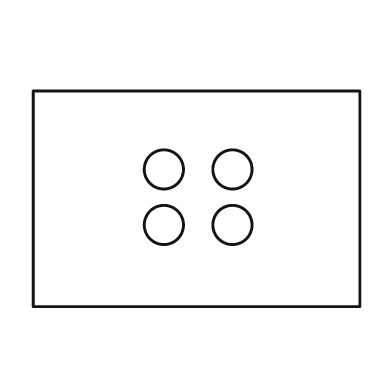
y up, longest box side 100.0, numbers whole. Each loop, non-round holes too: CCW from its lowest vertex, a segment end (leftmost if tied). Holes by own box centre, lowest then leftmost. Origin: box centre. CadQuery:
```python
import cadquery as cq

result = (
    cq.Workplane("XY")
    .moveTo(-50.0, -33.0)
    .lineTo(50.0, -33.0)
    .lineTo(50.0, 33.0)
    .lineTo(-50.0, 33.0)
    .close()
    .moveTo(-10.0, -8.0)
    .circle(6.0)
    .moveTo(11.0, -8.0)
    .circle(6.0)
    .moveTo(-10.0, 9.0)
    .circle(6.0)
    .moveTo(11.0, 9.0)
    .circle(6.0)
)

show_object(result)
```